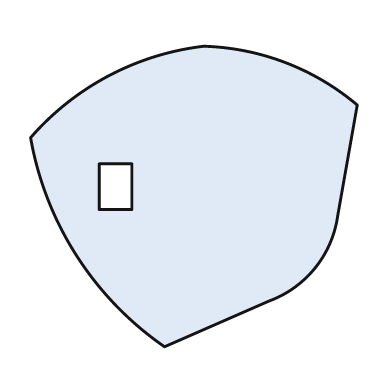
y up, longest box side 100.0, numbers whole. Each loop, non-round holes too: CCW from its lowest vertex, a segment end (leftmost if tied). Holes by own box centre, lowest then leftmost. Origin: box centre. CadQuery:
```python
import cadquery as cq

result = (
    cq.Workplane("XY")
    .moveTo(-9.0, -46.0)
    .lineTo(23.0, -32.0)
    .threePointArc((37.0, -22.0), (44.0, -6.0))
    .lineTo(50.0, 28.0)
    .threePointArc((28.0, 41.0), (3.0, 46.0))
    .threePointArc((-26.0, 37.0), (-50.0, 18.0))
    .threePointArc((-36.0, -18.0), (-9.0, -46.0))
    .close()
    .moveTo(-29.0, -4.0)
    .lineTo(-19.0, -4.0)
    .lineTo(-19.0, 10.0)
    .lineTo(-29.0, 10.0)
    .close()
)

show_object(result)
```